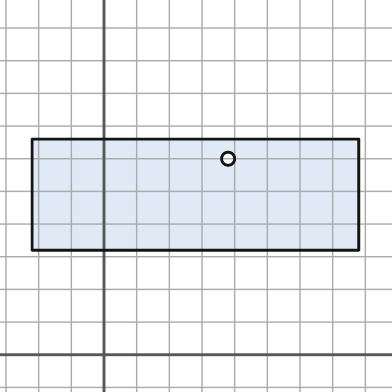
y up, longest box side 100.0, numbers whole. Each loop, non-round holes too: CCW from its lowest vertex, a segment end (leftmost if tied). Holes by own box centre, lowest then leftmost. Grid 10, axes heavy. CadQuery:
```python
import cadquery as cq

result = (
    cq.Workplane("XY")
    .moveTo(-22.0, 32.0)
    .lineTo(78.0, 32.0)
    .lineTo(78.0, 66.0)
    .lineTo(-22.0, 66.0)
    .close()
    .moveTo(38.0, 60.0)
    .circle(2.0)
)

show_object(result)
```